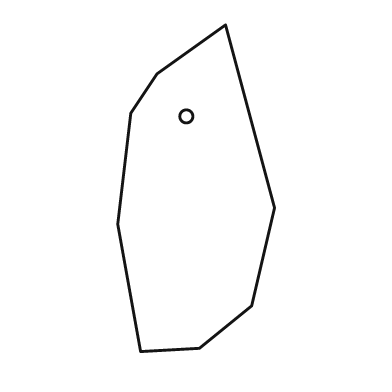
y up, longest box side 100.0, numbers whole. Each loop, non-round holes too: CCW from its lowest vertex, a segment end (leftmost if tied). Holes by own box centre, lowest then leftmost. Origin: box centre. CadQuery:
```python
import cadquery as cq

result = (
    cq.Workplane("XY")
    .moveTo(-17.0, -50.0)
    .lineTo(1.0, -49.0)
    .lineTo(17.0, -36.0)
    .lineTo(24.0, -6.0)
    .lineTo(9.0, 50.0)
    .lineTo(-12.0, 35.0)
    .lineTo(-20.0, 23.0)
    .lineTo(-24.0, -11.0)
    .close()
    .moveTo(-3.0, 22.0)
    .circle(2.0)
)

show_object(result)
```